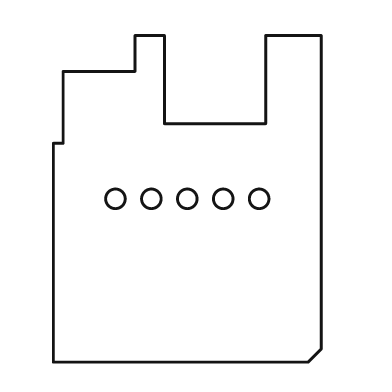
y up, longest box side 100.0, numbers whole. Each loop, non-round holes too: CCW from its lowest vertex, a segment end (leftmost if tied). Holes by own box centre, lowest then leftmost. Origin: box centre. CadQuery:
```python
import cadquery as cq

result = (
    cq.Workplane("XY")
    .moveTo(-41.0, -50.0)
    .lineTo(37.0, -50.0)
    .lineTo(41.0, -46.0)
    .lineTo(41.0, 50.0)
    .lineTo(24.0, 50.0)
    .lineTo(24.0, 23.0)
    .lineTo(-7.0, 23.0)
    .lineTo(-7.0, 50.0)
    .lineTo(-16.0, 50.0)
    .lineTo(-16.0, 39.0)
    .lineTo(-38.0, 39.0)
    .lineTo(-38.0, 17.0)
    .lineTo(-41.0, 17.0)
    .close()
    .moveTo(-22.0, 0.0)
    .circle(3.0)
    .moveTo(-11.0, 0.0)
    .circle(3.0)
    .moveTo(0.0, 0.0)
    .circle(3.0)
    .moveTo(11.0, 0.0)
    .circle(3.0)
    .moveTo(22.0, 0.0)
    .circle(3.0)
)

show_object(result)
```